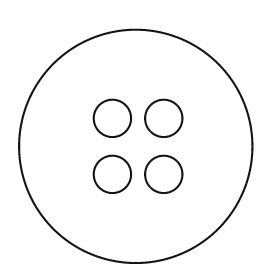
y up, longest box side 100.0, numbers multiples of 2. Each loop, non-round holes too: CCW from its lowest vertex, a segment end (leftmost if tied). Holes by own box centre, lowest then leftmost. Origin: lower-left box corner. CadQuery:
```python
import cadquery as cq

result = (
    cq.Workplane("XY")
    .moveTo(50.0, 50.0)
    .circle(50.0)
    .moveTo(40.0, 38.0)
    .circle(8.0)
    .moveTo(62.0, 38.0)
    .circle(8.0)
    .moveTo(40.0, 62.0)
    .circle(8.0)
    .moveTo(62.0, 62.0)
    .circle(8.0)
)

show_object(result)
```